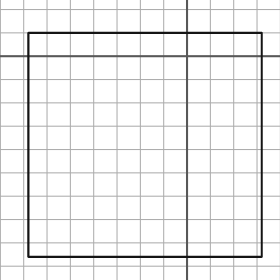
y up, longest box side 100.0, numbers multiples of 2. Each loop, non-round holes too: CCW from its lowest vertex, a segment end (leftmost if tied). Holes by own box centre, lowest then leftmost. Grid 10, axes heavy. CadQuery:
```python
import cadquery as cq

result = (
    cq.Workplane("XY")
    .moveTo(-68.0, -86.0)
    .lineTo(32.0, -86.0)
    .lineTo(32.0, 10.0)
    .lineTo(-68.0, 10.0)
    .close()
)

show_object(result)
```